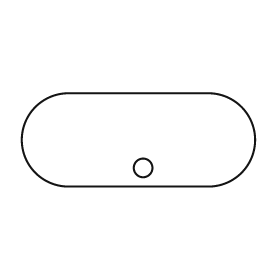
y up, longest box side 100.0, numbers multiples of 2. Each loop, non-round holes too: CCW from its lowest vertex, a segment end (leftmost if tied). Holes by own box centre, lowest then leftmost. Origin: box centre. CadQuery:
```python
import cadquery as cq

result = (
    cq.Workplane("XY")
    .moveTo(-30.0, -20.0)
    .lineTo(30.0, -20.0)
    .threePointArc((50.0, 0.0), (30.0, 20.0))
    .lineTo(-30.0, 20.0)
    .threePointArc((-50.0, 0.0), (-30.0, -20.0))
    .close()
    .moveTo(2.0, -12.0)
    .circle(4.0)
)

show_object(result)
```